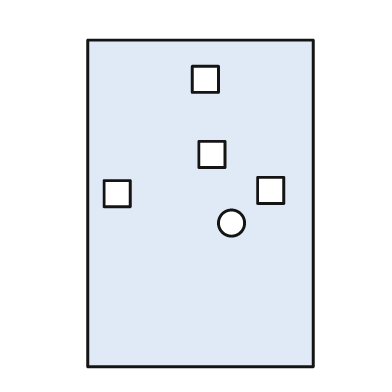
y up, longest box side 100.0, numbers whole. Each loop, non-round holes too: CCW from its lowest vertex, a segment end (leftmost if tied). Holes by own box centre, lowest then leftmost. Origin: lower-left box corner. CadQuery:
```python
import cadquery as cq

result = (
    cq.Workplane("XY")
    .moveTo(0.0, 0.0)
    .lineTo(69.0, 0.0)
    .lineTo(69.0, 100.0)
    .lineTo(0.0, 100.0)
    .close()
    .moveTo(44.0, 44.0)
    .circle(4.0)
    .moveTo(5.0, 49.0)
    .lineTo(13.0, 49.0)
    .lineTo(13.0, 57.0)
    .lineTo(5.0, 57.0)
    .close()
    .moveTo(52.0, 50.0)
    .lineTo(60.0, 50.0)
    .lineTo(60.0, 58.0)
    .lineTo(52.0, 58.0)
    .close()
    .moveTo(34.0, 61.0)
    .lineTo(42.0, 61.0)
    .lineTo(42.0, 69.0)
    .lineTo(34.0, 69.0)
    .close()
    .moveTo(32.0, 84.0)
    .lineTo(40.0, 84.0)
    .lineTo(40.0, 92.0)
    .lineTo(32.0, 92.0)
    .close()
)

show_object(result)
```